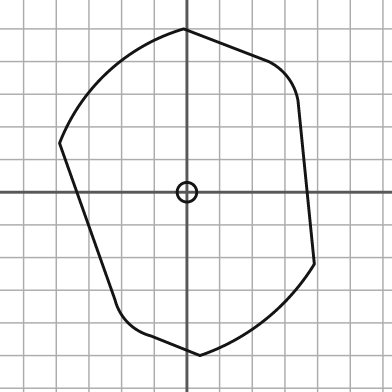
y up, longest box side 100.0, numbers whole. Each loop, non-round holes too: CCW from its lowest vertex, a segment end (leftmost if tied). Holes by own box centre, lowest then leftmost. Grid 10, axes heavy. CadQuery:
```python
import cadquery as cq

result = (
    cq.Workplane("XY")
    .moveTo(4.0, -50.0)
    .threePointArc((24.0, -39.0), (39.0, -22.0))
    .lineTo(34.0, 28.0)
    .threePointArc((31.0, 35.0), (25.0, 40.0))
    .lineTo(-1.0, 50.0)
    .threePointArc((-24.0, 37.0), (-39.0, 15.0))
    .lineTo(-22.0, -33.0)
    .threePointArc((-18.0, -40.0), (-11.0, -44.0))
    .close()
    .moveTo(0.0, 0.0)
    .circle(3.0)
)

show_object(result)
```